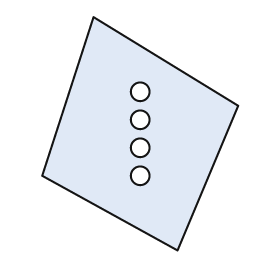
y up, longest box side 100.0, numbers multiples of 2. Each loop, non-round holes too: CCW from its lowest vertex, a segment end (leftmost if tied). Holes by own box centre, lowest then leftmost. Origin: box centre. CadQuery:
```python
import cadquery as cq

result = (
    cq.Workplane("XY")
    .moveTo(16.0, -50.0)
    .lineTo(42.0, 12.0)
    .lineTo(-20.0, 50.0)
    .lineTo(-42.0, -18.0)
    .close()
    .moveTo(0.0, -18.0)
    .circle(4.0)
    .moveTo(0.0, -6.0)
    .circle(4.0)
    .moveTo(0.0, 6.0)
    .circle(4.0)
    .moveTo(0.0, 18.0)
    .circle(4.0)
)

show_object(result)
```